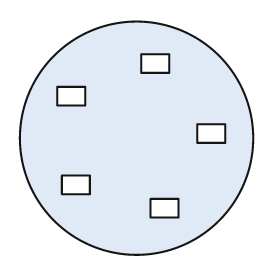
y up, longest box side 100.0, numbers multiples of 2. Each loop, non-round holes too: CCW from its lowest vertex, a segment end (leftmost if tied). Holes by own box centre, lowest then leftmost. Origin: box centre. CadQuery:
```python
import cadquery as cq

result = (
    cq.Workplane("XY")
    .moveTo(0.0, 0.0)
    .circle(50.0)
    .moveTo(6.0, -34.0)
    .lineTo(18.0, -34.0)
    .lineTo(18.0, -26.0)
    .lineTo(6.0, -26.0)
    .close()
    .moveTo(-32.0, -24.0)
    .lineTo(-20.0, -24.0)
    .lineTo(-20.0, -16.0)
    .lineTo(-32.0, -16.0)
    .close()
    .moveTo(26.0, -2.0)
    .lineTo(38.0, -2.0)
    .lineTo(38.0, 6.0)
    .lineTo(26.0, 6.0)
    .close()
    .moveTo(-34.0, 14.0)
    .lineTo(-22.0, 14.0)
    .lineTo(-22.0, 22.0)
    .lineTo(-34.0, 22.0)
    .close()
    .moveTo(2.0, 28.0)
    .lineTo(14.0, 28.0)
    .lineTo(14.0, 36.0)
    .lineTo(2.0, 36.0)
    .close()
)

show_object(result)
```